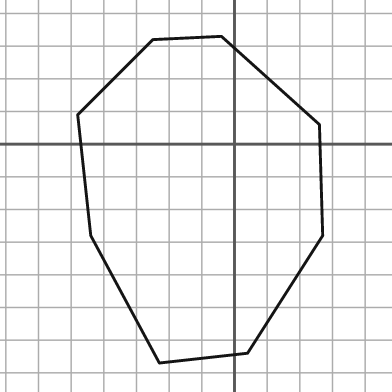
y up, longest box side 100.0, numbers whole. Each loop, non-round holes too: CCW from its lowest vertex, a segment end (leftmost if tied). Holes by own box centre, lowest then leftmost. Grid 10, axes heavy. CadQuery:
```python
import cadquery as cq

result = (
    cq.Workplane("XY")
    .moveTo(-23.0, -67.0)
    .lineTo(4.0, -64.0)
    .lineTo(27.0, -28.0)
    .lineTo(26.0, 6.0)
    .lineTo(-4.0, 33.0)
    .lineTo(-25.0, 32.0)
    .lineTo(-48.0, 9.0)
    .lineTo(-44.0, -28.0)
    .close()
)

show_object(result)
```